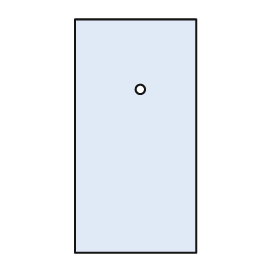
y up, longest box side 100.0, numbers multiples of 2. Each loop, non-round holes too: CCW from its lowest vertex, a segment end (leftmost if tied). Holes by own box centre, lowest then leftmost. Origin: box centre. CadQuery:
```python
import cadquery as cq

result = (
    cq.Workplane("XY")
    .moveTo(-26.0, -50.0)
    .lineTo(26.0, -50.0)
    .lineTo(26.0, 50.0)
    .lineTo(-26.0, 50.0)
    .close()
    .moveTo(2.0, 20.0)
    .circle(2.0)
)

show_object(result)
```